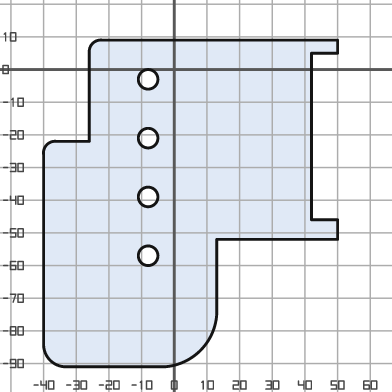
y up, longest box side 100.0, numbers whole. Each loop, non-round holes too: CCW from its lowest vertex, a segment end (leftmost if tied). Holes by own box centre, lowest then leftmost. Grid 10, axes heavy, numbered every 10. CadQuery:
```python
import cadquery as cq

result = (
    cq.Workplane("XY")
    .moveTo(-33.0, -91.0)
    .lineTo(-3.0, -91.0)
    .threePointArc((8.0, -86.0), (13.0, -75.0))
    .lineTo(13.0, -52.0)
    .lineTo(50.0, -52.0)
    .lineTo(50.0, -46.0)
    .lineTo(42.0, -46.0)
    .lineTo(42.0, 5.0)
    .lineTo(50.0, 5.0)
    .lineTo(50.0, 9.0)
    .lineTo(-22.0, 9.0)
    .threePointArc((-25.0, 8.0), (-26.0, 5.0))
    .lineTo(-26.0, -22.0)
    .lineTo(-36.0, -22.0)
    .threePointArc((-39.0, -23.0), (-40.0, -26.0))
    .lineTo(-40.0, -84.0)
    .threePointArc((-38.0, -89.0), (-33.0, -91.0))
    .close()
    .moveTo(-8.0, -57.0)
    .circle(3.0)
    .moveTo(-8.0, -39.0)
    .circle(3.0)
    .moveTo(-8.0, -21.0)
    .circle(3.0)
    .moveTo(-8.0, -3.0)
    .circle(3.0)
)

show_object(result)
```